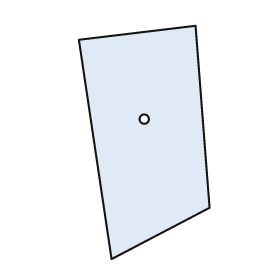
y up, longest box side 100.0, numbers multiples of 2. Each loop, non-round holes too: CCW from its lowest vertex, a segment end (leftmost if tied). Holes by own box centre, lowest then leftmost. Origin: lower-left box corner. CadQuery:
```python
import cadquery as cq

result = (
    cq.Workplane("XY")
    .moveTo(14.0, 0.0)
    .lineTo(56.0, 22.0)
    .lineTo(50.0, 100.0)
    .lineTo(0.0, 94.0)
    .close()
    .moveTo(28.0, 60.0)
    .circle(2.0)
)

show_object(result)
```